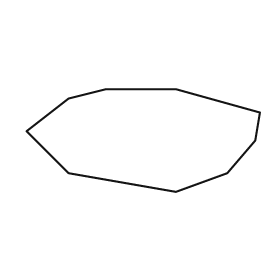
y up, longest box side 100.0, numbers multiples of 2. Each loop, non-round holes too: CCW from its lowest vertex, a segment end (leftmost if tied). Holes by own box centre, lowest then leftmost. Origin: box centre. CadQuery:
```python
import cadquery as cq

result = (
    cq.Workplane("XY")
    .moveTo(14.0, -22.0)
    .lineTo(36.0, -14.0)
    .lineTo(48.0, 0.0)
    .lineTo(50.0, 12.0)
    .lineTo(14.0, 22.0)
    .lineTo(-16.0, 22.0)
    .lineTo(-32.0, 18.0)
    .lineTo(-50.0, 4.0)
    .lineTo(-32.0, -14.0)
    .close()
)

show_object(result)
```